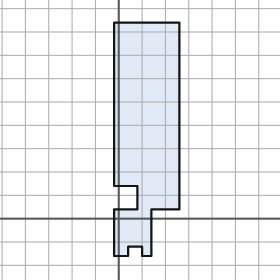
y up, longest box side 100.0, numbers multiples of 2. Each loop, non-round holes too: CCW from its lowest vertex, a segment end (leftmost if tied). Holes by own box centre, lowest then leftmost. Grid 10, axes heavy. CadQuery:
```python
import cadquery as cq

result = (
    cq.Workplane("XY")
    .moveTo(-2.0, -16.0)
    .lineTo(4.0, -16.0)
    .lineTo(4.0, -12.0)
    .lineTo(10.0, -12.0)
    .lineTo(10.0, -16.0)
    .lineTo(14.0, -16.0)
    .lineTo(14.0, 4.0)
    .lineTo(26.0, 4.0)
    .lineTo(26.0, 84.0)
    .lineTo(-2.0, 84.0)
    .lineTo(-2.0, 14.0)
    .lineTo(8.0, 14.0)
    .lineTo(8.0, 4.0)
    .lineTo(-2.0, 4.0)
    .close()
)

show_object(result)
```